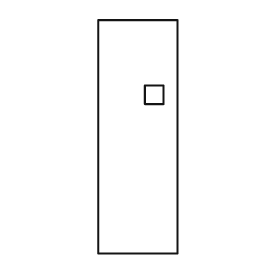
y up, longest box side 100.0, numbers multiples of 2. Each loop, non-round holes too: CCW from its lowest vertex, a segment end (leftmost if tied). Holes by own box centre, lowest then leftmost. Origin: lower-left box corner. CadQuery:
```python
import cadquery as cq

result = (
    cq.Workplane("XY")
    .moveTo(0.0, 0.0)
    .lineTo(34.0, 0.0)
    .lineTo(34.0, 100.0)
    .lineTo(0.0, 100.0)
    .close()
    .moveTo(20.0, 64.0)
    .lineTo(28.0, 64.0)
    .lineTo(28.0, 72.0)
    .lineTo(20.0, 72.0)
    .close()
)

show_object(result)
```